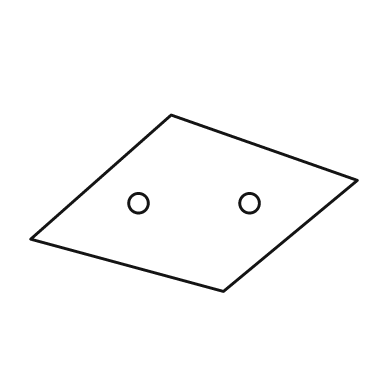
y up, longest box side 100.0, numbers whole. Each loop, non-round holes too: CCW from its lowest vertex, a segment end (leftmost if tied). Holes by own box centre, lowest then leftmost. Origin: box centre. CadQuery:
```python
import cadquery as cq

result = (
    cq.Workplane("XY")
    .moveTo(9.0, -27.0)
    .lineTo(50.0, 7.0)
    .lineTo(-7.0, 27.0)
    .lineTo(-50.0, -11.0)
    .close()
    .moveTo(-17.0, 0.0)
    .circle(3.0)
    .moveTo(17.0, 0.0)
    .circle(3.0)
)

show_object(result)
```